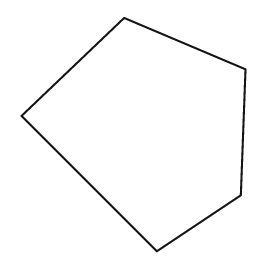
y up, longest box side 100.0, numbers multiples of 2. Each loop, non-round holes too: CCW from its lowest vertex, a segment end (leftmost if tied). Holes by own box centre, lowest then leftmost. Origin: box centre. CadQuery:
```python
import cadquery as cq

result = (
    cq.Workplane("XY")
    .moveTo(10.0, -50.0)
    .lineTo(46.0, -26.0)
    .lineTo(48.0, 28.0)
    .lineTo(-4.0, 50.0)
    .lineTo(-48.0, 8.0)
    .close()
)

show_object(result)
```